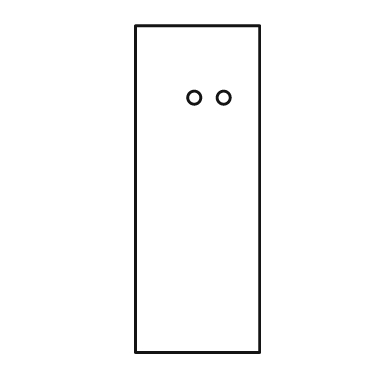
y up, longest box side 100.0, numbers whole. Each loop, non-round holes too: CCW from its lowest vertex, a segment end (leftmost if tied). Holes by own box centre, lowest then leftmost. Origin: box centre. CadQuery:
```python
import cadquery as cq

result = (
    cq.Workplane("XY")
    .moveTo(-19.0, -50.0)
    .lineTo(19.0, -50.0)
    .lineTo(19.0, 50.0)
    .lineTo(-19.0, 50.0)
    .close()
    .moveTo(-1.0, 28.0)
    .circle(2.0)
    .moveTo(8.0, 28.0)
    .circle(2.0)
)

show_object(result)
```